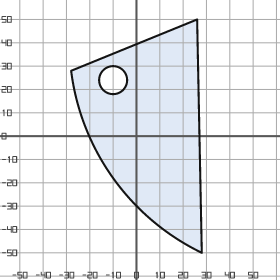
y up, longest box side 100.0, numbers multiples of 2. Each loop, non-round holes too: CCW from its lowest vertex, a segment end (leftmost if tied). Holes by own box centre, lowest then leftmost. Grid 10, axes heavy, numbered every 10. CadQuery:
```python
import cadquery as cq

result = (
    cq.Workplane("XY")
    .moveTo(28.0, -50.0)
    .lineTo(26.0, 50.0)
    .lineTo(-28.0, 28.0)
    .threePointArc((-10.0, -18.0), (28.0, -50.0))
    .close()
    .moveTo(-10.0, 24.0)
    .circle(6.0)
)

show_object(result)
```